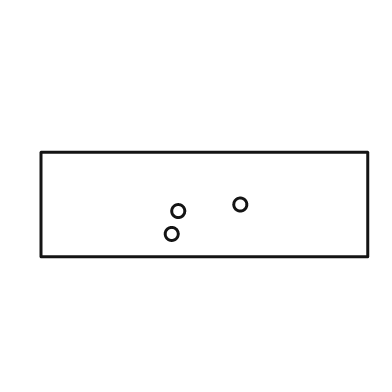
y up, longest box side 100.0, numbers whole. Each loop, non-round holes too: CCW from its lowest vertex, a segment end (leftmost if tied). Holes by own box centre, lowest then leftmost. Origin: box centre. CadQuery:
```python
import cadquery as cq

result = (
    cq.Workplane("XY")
    .moveTo(-50.0, -16.0)
    .lineTo(50.0, -16.0)
    .lineTo(50.0, 16.0)
    .lineTo(-50.0, 16.0)
    .close()
    .moveTo(-10.0, -9.0)
    .circle(2.0)
    .moveTo(-8.0, -2.0)
    .circle(2.0)
    .moveTo(11.0, 0.0)
    .circle(2.0)
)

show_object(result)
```